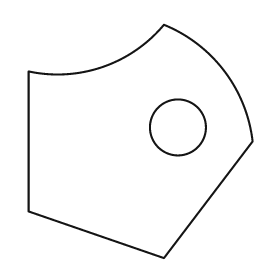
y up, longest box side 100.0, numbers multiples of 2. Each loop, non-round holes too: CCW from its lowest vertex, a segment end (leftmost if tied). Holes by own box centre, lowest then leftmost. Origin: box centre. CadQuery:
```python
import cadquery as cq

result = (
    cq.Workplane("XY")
    .moveTo(10.0, -50.0)
    .lineTo(48.0, 0.0)
    .threePointArc((36.0, 30.0), (10.0, 50.0))
    .threePointArc((-16.0, 32.0), (-48.0, 30.0))
    .lineTo(-48.0, -30.0)
    .close()
    .moveTo(16.0, 6.0)
    .circle(12.0)
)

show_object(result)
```